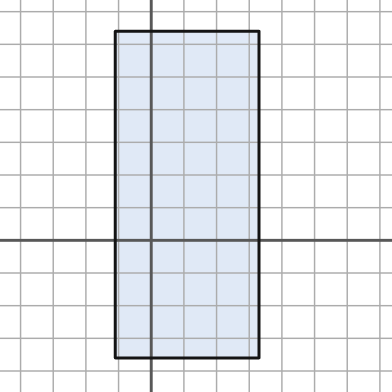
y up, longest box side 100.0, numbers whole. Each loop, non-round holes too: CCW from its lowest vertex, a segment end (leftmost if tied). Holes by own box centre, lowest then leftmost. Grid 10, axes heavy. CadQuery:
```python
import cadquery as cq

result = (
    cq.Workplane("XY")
    .moveTo(-11.0, -36.0)
    .lineTo(33.0, -36.0)
    .lineTo(33.0, 64.0)
    .lineTo(-11.0, 64.0)
    .close()
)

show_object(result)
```